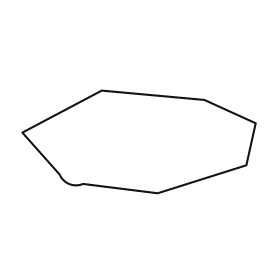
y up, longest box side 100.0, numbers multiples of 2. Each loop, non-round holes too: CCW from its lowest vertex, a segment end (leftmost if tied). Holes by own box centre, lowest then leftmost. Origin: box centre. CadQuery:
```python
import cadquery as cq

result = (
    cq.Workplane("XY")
    .moveTo(8.0, -22.0)
    .lineTo(46.0, -10.0)
    .lineTo(50.0, 8.0)
    .lineTo(28.0, 18.0)
    .lineTo(-16.0, 22.0)
    .lineTo(-50.0, 4.0)
    .lineTo(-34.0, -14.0)
    .threePointArc((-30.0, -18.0), (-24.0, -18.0))
    .close()
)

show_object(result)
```